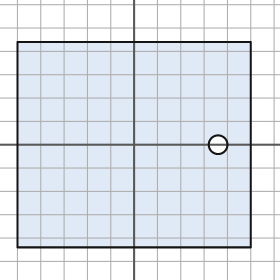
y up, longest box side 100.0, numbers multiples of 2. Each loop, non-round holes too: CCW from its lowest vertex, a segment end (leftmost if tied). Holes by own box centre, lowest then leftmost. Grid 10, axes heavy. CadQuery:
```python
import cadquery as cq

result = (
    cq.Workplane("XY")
    .moveTo(-50.0, -44.0)
    .lineTo(50.0, -44.0)
    .lineTo(50.0, 44.0)
    .lineTo(-50.0, 44.0)
    .close()
    .moveTo(36.0, 0.0)
    .circle(4.0)
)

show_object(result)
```